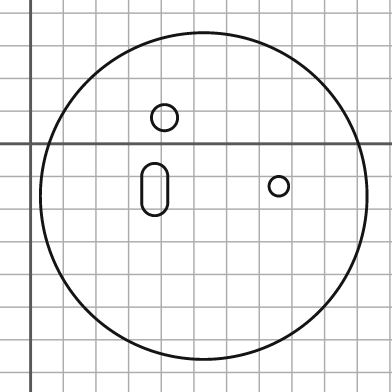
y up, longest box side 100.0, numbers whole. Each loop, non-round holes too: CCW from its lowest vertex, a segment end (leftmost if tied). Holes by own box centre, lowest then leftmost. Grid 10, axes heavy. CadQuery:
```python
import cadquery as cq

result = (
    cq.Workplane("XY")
    .moveTo(53.0, -16.0)
    .circle(50.0)
    .moveTo(34.0, -18.0)
    .threePointArc((38.0, -22.0), (42.0, -18.0))
    .lineTo(42.0, -10.0)
    .threePointArc((38.0, -6.0), (34.0, -10.0))
    .close()
    .moveTo(76.0, -13.0)
    .circle(3.0)
    .moveTo(41.0, 8.0)
    .circle(4.0)
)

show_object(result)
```